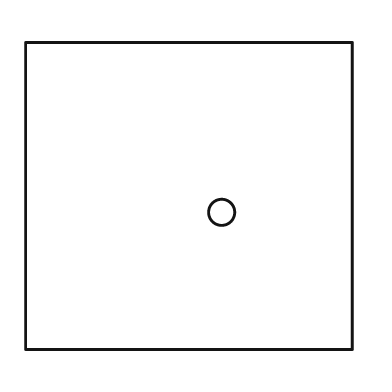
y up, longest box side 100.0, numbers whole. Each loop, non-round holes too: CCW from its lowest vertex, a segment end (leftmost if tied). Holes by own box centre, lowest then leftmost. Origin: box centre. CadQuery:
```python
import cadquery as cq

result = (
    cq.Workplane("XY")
    .moveTo(-50.0, -47.0)
    .lineTo(50.0, -47.0)
    .lineTo(50.0, 47.0)
    .lineTo(-50.0, 47.0)
    .close()
    .moveTo(10.0, -5.0)
    .circle(4.0)
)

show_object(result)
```